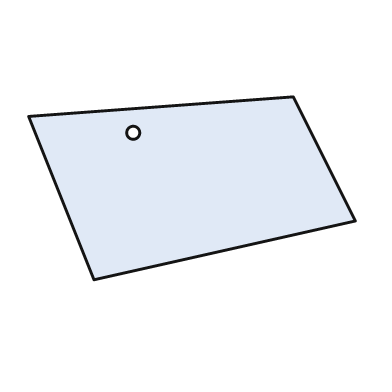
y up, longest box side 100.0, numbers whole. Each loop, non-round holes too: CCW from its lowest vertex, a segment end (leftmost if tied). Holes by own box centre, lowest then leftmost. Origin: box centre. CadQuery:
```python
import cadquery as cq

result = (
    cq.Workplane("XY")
    .moveTo(-30.0, -28.0)
    .lineTo(50.0, -10.0)
    .lineTo(31.0, 28.0)
    .lineTo(-50.0, 22.0)
    .close()
    .moveTo(-18.0, 17.0)
    .circle(2.0)
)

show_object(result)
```